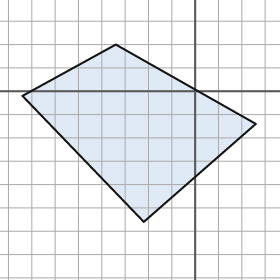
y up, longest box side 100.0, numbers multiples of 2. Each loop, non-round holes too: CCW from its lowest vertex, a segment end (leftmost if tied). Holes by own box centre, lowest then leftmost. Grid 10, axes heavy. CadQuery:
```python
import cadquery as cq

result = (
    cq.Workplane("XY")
    .moveTo(-22.0, -56.0)
    .lineTo(26.0, -14.0)
    .lineTo(-34.0, 20.0)
    .lineTo(-74.0, -2.0)
    .close()
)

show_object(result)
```